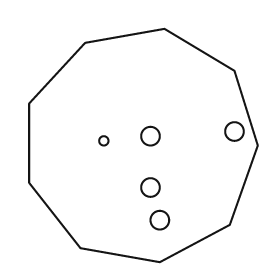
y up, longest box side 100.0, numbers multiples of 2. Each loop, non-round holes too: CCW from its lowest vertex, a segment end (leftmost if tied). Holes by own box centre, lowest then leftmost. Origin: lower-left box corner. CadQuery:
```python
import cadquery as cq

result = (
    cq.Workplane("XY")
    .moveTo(56.0, 0.0)
    .lineTo(86.0, 16.0)
    .lineTo(98.0, 50.0)
    .lineTo(88.0, 82.0)
    .lineTo(58.0, 100.0)
    .lineTo(24.0, 94.0)
    .lineTo(0.0, 68.0)
    .lineTo(0.0, 34.0)
    .lineTo(22.0, 6.0)
    .close()
    .moveTo(56.0, 18.0)
    .circle(4.0)
    .moveTo(52.0, 32.0)
    .circle(4.0)
    .moveTo(32.0, 52.0)
    .circle(2.0)
    .moveTo(52.0, 54.0)
    .circle(4.0)
    .moveTo(88.0, 56.0)
    .circle(4.0)
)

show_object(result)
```